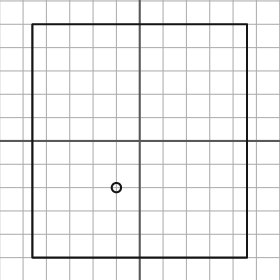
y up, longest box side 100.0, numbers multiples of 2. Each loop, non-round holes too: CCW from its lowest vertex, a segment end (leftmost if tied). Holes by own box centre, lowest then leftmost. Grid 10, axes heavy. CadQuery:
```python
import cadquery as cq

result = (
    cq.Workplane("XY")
    .moveTo(-46.0, -50.0)
    .lineTo(46.0, -50.0)
    .lineTo(46.0, 50.0)
    .lineTo(-46.0, 50.0)
    .close()
    .moveTo(-10.0, -20.0)
    .circle(2.0)
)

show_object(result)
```